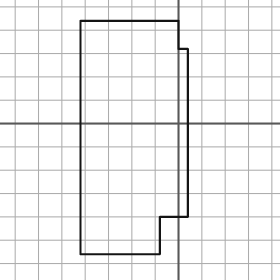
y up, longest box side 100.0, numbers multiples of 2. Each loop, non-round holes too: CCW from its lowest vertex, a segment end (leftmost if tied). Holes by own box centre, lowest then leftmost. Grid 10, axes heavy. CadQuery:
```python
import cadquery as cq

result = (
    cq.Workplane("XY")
    .moveTo(-42.0, -56.0)
    .lineTo(-8.0, -56.0)
    .lineTo(-8.0, -40.0)
    .lineTo(4.0, -40.0)
    .lineTo(4.0, 32.0)
    .lineTo(0.0, 32.0)
    .lineTo(0.0, 44.0)
    .lineTo(-42.0, 44.0)
    .close()
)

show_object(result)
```